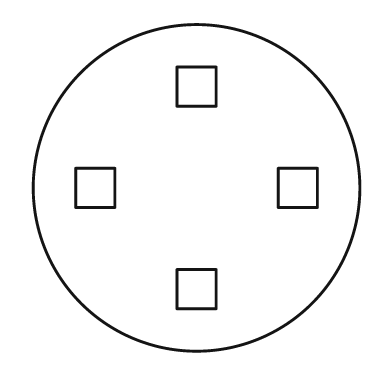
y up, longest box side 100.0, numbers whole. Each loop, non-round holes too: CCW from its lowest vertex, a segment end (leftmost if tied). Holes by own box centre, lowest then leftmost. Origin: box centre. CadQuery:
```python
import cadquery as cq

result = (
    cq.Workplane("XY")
    .moveTo(0.0, 0.0)
    .circle(50.0)
    .moveTo(-6.0, -37.0)
    .lineTo(6.0, -37.0)
    .lineTo(6.0, -25.0)
    .lineTo(-6.0, -25.0)
    .close()
    .moveTo(-37.0, -6.0)
    .lineTo(-25.0, -6.0)
    .lineTo(-25.0, 6.0)
    .lineTo(-37.0, 6.0)
    .close()
    .moveTo(25.0, -6.0)
    .lineTo(37.0, -6.0)
    .lineTo(37.0, 6.0)
    .lineTo(25.0, 6.0)
    .close()
    .moveTo(-6.0, 25.0)
    .lineTo(6.0, 25.0)
    .lineTo(6.0, 37.0)
    .lineTo(-6.0, 37.0)
    .close()
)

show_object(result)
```